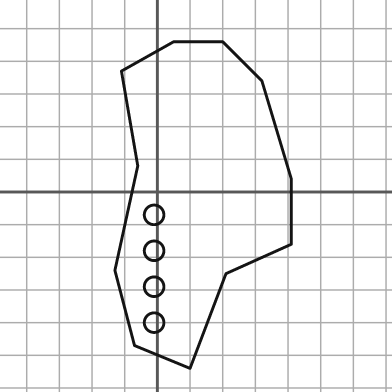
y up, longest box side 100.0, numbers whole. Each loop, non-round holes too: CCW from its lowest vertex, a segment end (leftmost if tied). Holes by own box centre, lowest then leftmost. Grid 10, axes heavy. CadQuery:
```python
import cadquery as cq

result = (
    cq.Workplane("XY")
    .moveTo(10.0, -54.0)
    .lineTo(21.0, -25.0)
    .lineTo(41.0, -16.0)
    .lineTo(41.0, 4.0)
    .lineTo(32.0, 34.0)
    .lineTo(20.0, 46.0)
    .lineTo(5.0, 46.0)
    .lineTo(-11.0, 37.0)
    .lineTo(-6.0, 8.0)
    .lineTo(-13.0, -24.0)
    .lineTo(-7.0, -47.0)
    .close()
    .moveTo(-1.0, -40.0)
    .circle(3.0)
    .moveTo(-1.0, -29.0)
    .circle(3.0)
    .moveTo(-1.0, -18.0)
    .circle(3.0)
    .moveTo(-1.0, -7.0)
    .circle(3.0)
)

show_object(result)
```